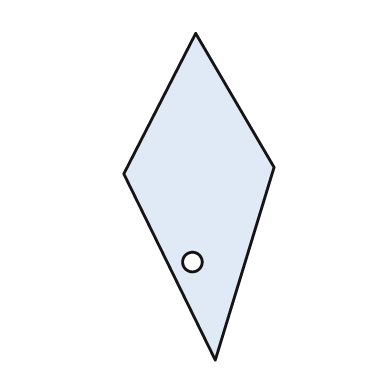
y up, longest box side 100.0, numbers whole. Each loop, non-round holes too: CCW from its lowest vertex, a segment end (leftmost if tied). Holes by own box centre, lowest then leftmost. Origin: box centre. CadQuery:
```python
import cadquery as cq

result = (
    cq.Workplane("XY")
    .moveTo(5.0, -50.0)
    .lineTo(23.0, 9.0)
    .lineTo(-1.0, 50.0)
    .lineTo(-23.0, 7.0)
    .close()
    .moveTo(-2.0, -20.0)
    .circle(3.0)
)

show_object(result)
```